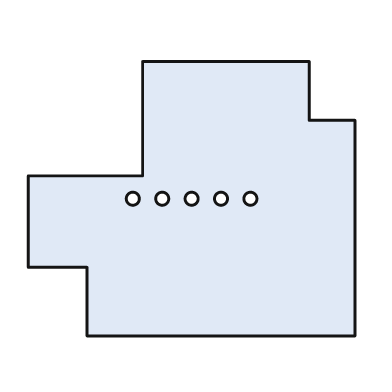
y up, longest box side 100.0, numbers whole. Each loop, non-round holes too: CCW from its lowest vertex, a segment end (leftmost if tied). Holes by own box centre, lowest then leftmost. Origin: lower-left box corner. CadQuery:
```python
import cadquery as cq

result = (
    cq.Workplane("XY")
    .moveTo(18.0, 0.0)
    .lineTo(100.0, 0.0)
    .lineTo(100.0, 66.0)
    .lineTo(86.0, 66.0)
    .lineTo(86.0, 84.0)
    .lineTo(35.0, 84.0)
    .lineTo(35.0, 49.0)
    .lineTo(0.0, 49.0)
    .lineTo(0.0, 21.0)
    .lineTo(18.0, 21.0)
    .close()
    .moveTo(32.0, 42.0)
    .circle(2.0)
    .moveTo(41.0, 42.0)
    .circle(2.0)
    .moveTo(50.0, 42.0)
    .circle(2.0)
    .moveTo(59.0, 42.0)
    .circle(2.0)
    .moveTo(68.0, 42.0)
    .circle(2.0)
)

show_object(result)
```